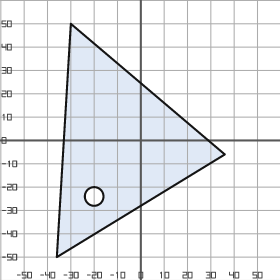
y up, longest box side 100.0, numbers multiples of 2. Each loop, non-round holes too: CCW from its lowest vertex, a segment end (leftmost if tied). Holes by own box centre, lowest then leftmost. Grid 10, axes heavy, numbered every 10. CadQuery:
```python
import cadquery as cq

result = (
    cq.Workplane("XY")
    .moveTo(-36.0, -50.0)
    .lineTo(36.0, -6.0)
    .lineTo(-30.0, 50.0)
    .close()
    .moveTo(-20.0, -24.0)
    .circle(4.0)
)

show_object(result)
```